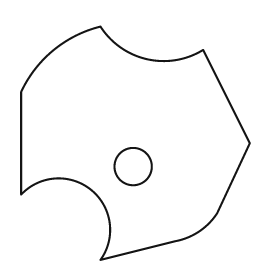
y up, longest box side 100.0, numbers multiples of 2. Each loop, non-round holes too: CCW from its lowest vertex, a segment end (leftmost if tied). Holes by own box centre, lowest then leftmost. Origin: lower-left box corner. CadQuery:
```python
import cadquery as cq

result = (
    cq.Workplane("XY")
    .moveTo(34.0, 0.0)
    .lineTo(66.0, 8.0)
    .threePointArc((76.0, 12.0), (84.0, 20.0))
    .lineTo(98.0, 50.0)
    .lineTo(78.0, 90.0)
    .threePointArc((54.0, 86.0), (34.0, 100.0))
    .threePointArc((14.0, 90.0), (0.0, 72.0))
    .lineTo(0.0, 28.0)
    .threePointArc((30.0, 30.0), (34.0, 0.0))
    .close()
    .moveTo(48.0, 40.0)
    .circle(8.0)
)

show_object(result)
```